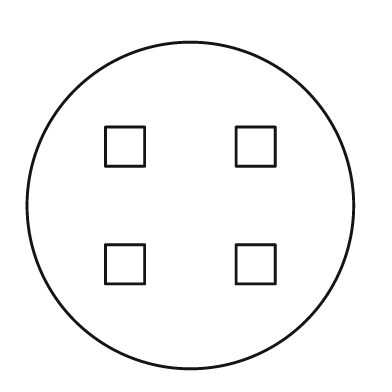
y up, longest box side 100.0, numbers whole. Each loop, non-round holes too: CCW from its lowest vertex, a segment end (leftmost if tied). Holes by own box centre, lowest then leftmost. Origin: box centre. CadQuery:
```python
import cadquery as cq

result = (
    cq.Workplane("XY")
    .moveTo(0.0, 0.0)
    .circle(50.0)
    .moveTo(-26.0, -24.0)
    .lineTo(-14.0, -24.0)
    .lineTo(-14.0, -12.0)
    .lineTo(-26.0, -12.0)
    .close()
    .moveTo(14.0, -24.0)
    .lineTo(26.0, -24.0)
    .lineTo(26.0, -12.0)
    .lineTo(14.0, -12.0)
    .close()
    .moveTo(-26.0, 12.0)
    .lineTo(-14.0, 12.0)
    .lineTo(-14.0, 24.0)
    .lineTo(-26.0, 24.0)
    .close()
    .moveTo(14.0, 12.0)
    .lineTo(26.0, 12.0)
    .lineTo(26.0, 24.0)
    .lineTo(14.0, 24.0)
    .close()
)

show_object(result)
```